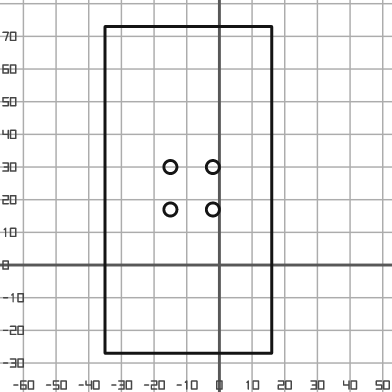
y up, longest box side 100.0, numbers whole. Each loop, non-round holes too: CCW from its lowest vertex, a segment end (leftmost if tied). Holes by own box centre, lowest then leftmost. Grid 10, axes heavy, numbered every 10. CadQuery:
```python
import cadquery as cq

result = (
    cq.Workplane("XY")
    .moveTo(-35.0, -27.0)
    .lineTo(16.0, -27.0)
    .lineTo(16.0, 73.0)
    .lineTo(-35.0, 73.0)
    .close()
    .moveTo(-15.0, 17.0)
    .circle(2.0)
    .moveTo(-2.0, 17.0)
    .circle(2.0)
    .moveTo(-15.0, 30.0)
    .circle(2.0)
    .moveTo(-2.0, 30.0)
    .circle(2.0)
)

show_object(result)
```